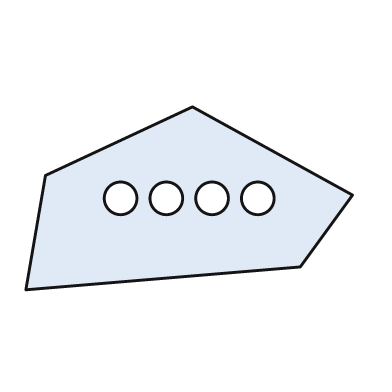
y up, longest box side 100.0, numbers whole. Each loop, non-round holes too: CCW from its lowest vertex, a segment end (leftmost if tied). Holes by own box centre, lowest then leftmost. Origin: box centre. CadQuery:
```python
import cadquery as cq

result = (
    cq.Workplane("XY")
    .moveTo(-50.0, -28.0)
    .lineTo(34.0, -21.0)
    .lineTo(50.0, 1.0)
    .lineTo(1.0, 28.0)
    .lineTo(-44.0, 7.0)
    .close()
    .moveTo(-21.0, 0.0)
    .circle(5.0)
    .moveTo(-7.0, 0.0)
    .circle(5.0)
    .moveTo(7.0, 0.0)
    .circle(5.0)
    .moveTo(21.0, 0.0)
    .circle(5.0)
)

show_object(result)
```